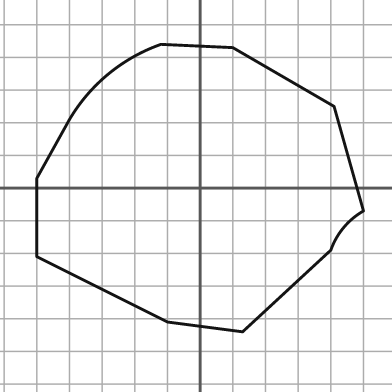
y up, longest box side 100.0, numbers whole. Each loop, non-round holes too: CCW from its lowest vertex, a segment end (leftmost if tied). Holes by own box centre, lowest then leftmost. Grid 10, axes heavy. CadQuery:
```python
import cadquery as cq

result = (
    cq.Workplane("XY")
    .moveTo(13.0, -44.0)
    .lineTo(40.0, -19.0)
    .threePointArc((44.0, -12.0), (50.0, -7.0))
    .lineTo(41.0, 25.0)
    .lineTo(10.0, 43.0)
    .lineTo(-12.0, 44.0)
    .threePointArc((-28.0, 35.0), (-40.0, 21.0))
    .lineTo(-50.0, 3.0)
    .lineTo(-50.0, -21.0)
    .lineTo(-10.0, -41.0)
    .close()
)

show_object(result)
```